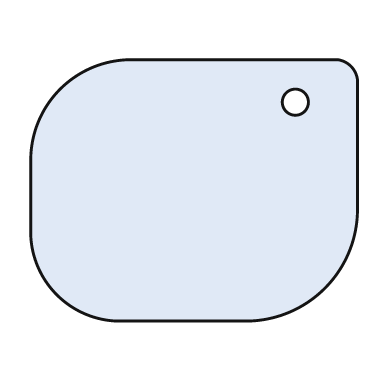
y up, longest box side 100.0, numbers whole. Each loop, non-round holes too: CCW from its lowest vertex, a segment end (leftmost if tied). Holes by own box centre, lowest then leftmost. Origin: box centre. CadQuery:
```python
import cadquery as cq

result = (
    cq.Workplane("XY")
    .moveTo(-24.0, -40.0)
    .lineTo(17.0, -40.0)
    .threePointArc((40.0, -30.0), (50.0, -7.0))
    .lineTo(50.0, 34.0)
    .threePointArc((48.0, 38.0), (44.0, 40.0))
    .lineTo(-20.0, 40.0)
    .threePointArc((-41.0, 31.0), (-50.0, 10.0))
    .lineTo(-50.0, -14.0)
    .threePointArc((-42.0, -32.0), (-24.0, -40.0))
    .close()
    .moveTo(31.0, 27.0)
    .circle(4.0)
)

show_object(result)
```